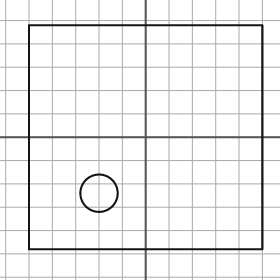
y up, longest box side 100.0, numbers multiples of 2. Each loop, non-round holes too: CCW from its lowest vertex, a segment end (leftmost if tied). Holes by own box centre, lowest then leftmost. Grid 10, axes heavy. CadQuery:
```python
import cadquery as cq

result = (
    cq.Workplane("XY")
    .moveTo(-50.0, -48.0)
    .lineTo(50.0, -48.0)
    .lineTo(50.0, 48.0)
    .lineTo(-50.0, 48.0)
    .close()
    .moveTo(-20.0, -24.0)
    .circle(8.0)
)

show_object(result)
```